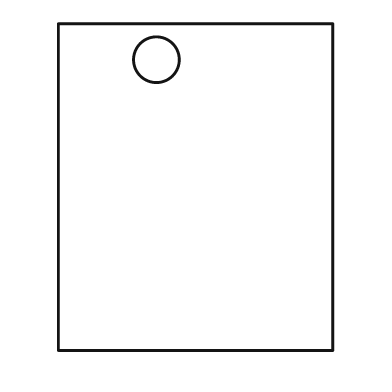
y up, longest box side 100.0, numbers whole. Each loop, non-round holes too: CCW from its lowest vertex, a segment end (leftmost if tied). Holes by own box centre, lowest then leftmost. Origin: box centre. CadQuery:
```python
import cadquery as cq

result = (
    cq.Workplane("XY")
    .moveTo(-42.0, -50.0)
    .lineTo(42.0, -50.0)
    .lineTo(42.0, 50.0)
    .lineTo(-42.0, 50.0)
    .close()
    .moveTo(-12.0, 39.0)
    .circle(7.0)
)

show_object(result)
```